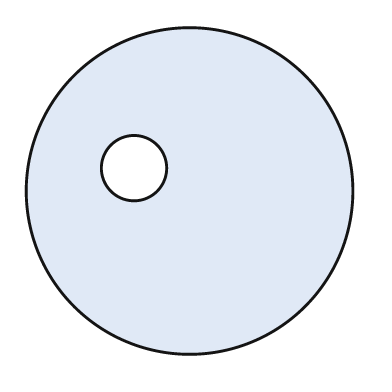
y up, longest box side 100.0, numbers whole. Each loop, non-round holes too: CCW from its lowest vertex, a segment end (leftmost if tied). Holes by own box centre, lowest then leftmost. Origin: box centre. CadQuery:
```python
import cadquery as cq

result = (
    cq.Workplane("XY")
    .moveTo(0.0, 0.0)
    .circle(50.0)
    .moveTo(-17.0, 7.0)
    .circle(10.0)
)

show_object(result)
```